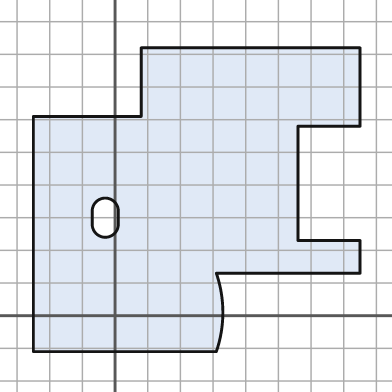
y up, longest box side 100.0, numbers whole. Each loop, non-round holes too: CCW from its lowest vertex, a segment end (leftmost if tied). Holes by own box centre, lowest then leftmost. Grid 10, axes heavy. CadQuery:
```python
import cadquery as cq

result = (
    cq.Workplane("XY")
    .moveTo(-25.0, -11.0)
    .lineTo(31.0, -11.0)
    .threePointArc((33.0, 1.0), (31.0, 13.0))
    .lineTo(75.0, 13.0)
    .lineTo(75.0, 23.0)
    .lineTo(56.0, 23.0)
    .lineTo(56.0, 58.0)
    .lineTo(75.0, 58.0)
    .lineTo(75.0, 82.0)
    .lineTo(8.0, 82.0)
    .lineTo(8.0, 61.0)
    .lineTo(-25.0, 61.0)
    .close()
    .moveTo(-7.0, 28.0)
    .threePointArc((-3.0, 24.0), (1.0, 28.0))
    .lineTo(1.0, 32.0)
    .threePointArc((-3.0, 36.0), (-7.0, 32.0))
    .close()
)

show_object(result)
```